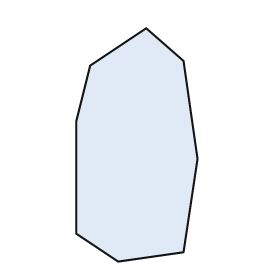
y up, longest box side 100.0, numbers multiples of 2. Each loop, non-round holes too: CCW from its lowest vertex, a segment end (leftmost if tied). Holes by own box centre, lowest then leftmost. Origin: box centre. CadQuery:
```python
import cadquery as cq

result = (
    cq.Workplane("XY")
    .moveTo(-8.0, -50.0)
    .lineTo(20.0, -46.0)
    .lineTo(26.0, -6.0)
    .lineTo(20.0, 36.0)
    .lineTo(4.0, 50.0)
    .lineTo(-20.0, 34.0)
    .lineTo(-26.0, 10.0)
    .lineTo(-26.0, -38.0)
    .close()
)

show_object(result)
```